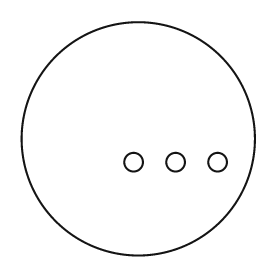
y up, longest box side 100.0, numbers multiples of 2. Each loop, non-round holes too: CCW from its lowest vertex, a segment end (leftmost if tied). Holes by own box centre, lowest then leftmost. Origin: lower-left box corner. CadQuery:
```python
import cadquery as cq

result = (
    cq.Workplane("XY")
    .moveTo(50.0, 50.0)
    .circle(50.0)
    .moveTo(48.0, 40.0)
    .circle(4.0)
    .moveTo(66.0, 40.0)
    .circle(4.0)
    .moveTo(84.0, 40.0)
    .circle(4.0)
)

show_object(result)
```